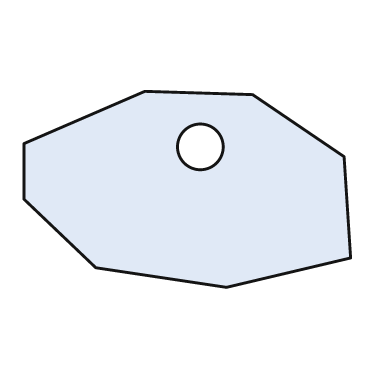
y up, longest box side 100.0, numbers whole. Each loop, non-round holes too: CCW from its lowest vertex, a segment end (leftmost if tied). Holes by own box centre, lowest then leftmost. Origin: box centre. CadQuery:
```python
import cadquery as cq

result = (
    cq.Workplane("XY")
    .moveTo(12.0, -30.0)
    .lineTo(50.0, -21.0)
    .lineTo(48.0, 10.0)
    .lineTo(20.0, 29.0)
    .lineTo(-13.0, 30.0)
    .lineTo(-50.0, 14.0)
    .lineTo(-50.0, -3.0)
    .lineTo(-28.0, -24.0)
    .close()
    .moveTo(4.0, 13.0)
    .circle(7.0)
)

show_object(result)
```